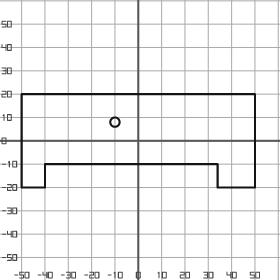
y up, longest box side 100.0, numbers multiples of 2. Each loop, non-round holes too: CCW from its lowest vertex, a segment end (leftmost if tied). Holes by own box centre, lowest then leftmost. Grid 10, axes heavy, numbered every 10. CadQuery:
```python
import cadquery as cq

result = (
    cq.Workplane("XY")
    .moveTo(-50.0, -20.0)
    .lineTo(-40.0, -20.0)
    .lineTo(-40.0, -10.0)
    .lineTo(34.0, -10.0)
    .lineTo(34.0, -20.0)
    .lineTo(50.0, -20.0)
    .lineTo(50.0, 20.0)
    .lineTo(-50.0, 20.0)
    .close()
    .moveTo(-10.0, 8.0)
    .circle(2.0)
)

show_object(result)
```